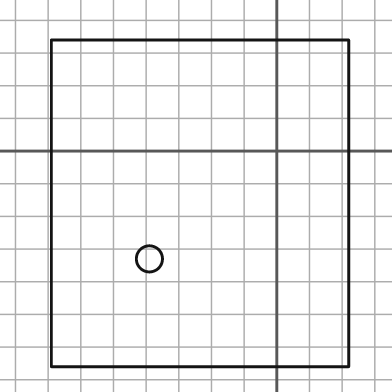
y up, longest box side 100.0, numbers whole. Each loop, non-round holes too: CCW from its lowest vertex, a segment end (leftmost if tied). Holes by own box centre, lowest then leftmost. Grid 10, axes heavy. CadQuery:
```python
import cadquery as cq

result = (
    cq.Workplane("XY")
    .moveTo(-69.0, -66.0)
    .lineTo(22.0, -66.0)
    .lineTo(22.0, 34.0)
    .lineTo(-69.0, 34.0)
    .close()
    .moveTo(-39.0, -33.0)
    .circle(4.0)
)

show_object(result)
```